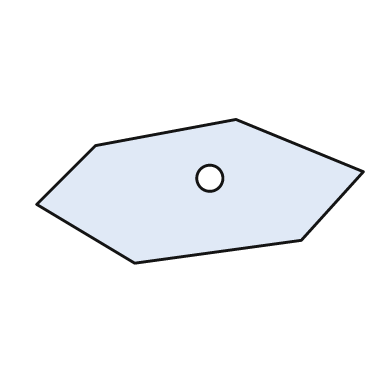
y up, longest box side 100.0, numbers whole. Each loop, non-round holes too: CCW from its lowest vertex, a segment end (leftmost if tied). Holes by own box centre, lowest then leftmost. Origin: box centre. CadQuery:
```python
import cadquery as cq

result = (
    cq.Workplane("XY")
    .moveTo(-20.0, -22.0)
    .lineTo(31.0, -15.0)
    .lineTo(50.0, 6.0)
    .lineTo(11.0, 22.0)
    .lineTo(-32.0, 14.0)
    .lineTo(-50.0, -4.0)
    .close()
    .moveTo(3.0, 4.0)
    .circle(4.0)
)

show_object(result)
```